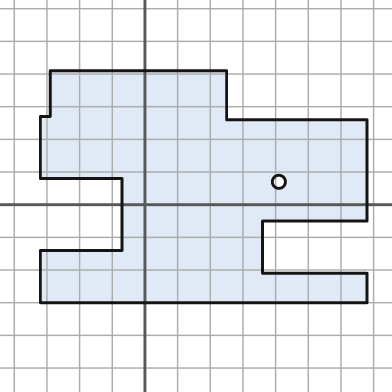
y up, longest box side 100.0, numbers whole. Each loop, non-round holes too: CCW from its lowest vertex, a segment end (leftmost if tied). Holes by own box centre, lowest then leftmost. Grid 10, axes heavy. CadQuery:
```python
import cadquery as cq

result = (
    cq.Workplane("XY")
    .moveTo(-32.0, -30.0)
    .lineTo(68.0, -30.0)
    .lineTo(68.0, -21.0)
    .lineTo(36.0, -21.0)
    .lineTo(36.0, -5.0)
    .lineTo(68.0, -5.0)
    .lineTo(68.0, 26.0)
    .lineTo(25.0, 26.0)
    .lineTo(25.0, 41.0)
    .lineTo(-29.0, 41.0)
    .lineTo(-29.0, 27.0)
    .lineTo(-32.0, 27.0)
    .lineTo(-32.0, 8.0)
    .lineTo(-7.0, 8.0)
    .lineTo(-7.0, -14.0)
    .lineTo(-32.0, -14.0)
    .close()
    .moveTo(41.0, 7.0)
    .circle(2.0)
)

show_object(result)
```